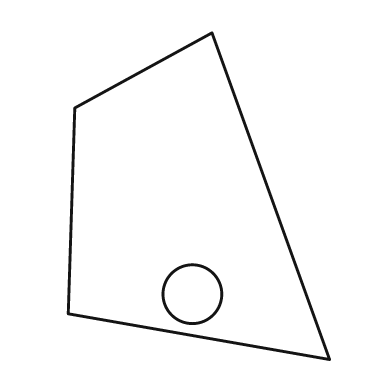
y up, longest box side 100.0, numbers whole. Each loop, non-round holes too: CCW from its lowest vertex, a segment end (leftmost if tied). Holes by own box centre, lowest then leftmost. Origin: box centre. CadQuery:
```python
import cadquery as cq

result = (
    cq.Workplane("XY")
    .moveTo(40.0, -50.0)
    .lineTo(4.0, 50.0)
    .lineTo(-38.0, 27.0)
    .lineTo(-40.0, -36.0)
    .close()
    .moveTo(-2.0, -30.0)
    .circle(9.0)
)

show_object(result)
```